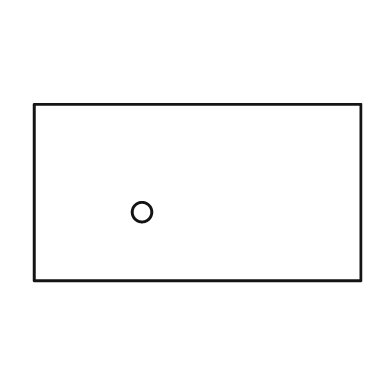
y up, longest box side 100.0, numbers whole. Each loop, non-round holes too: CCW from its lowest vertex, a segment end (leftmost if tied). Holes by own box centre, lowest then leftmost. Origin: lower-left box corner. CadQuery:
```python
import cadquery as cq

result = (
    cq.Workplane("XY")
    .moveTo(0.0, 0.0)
    .lineTo(100.0, 0.0)
    .lineTo(100.0, 54.0)
    .lineTo(0.0, 54.0)
    .close()
    .moveTo(33.0, 21.0)
    .circle(3.0)
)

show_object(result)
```